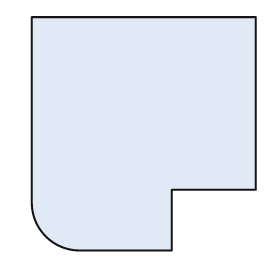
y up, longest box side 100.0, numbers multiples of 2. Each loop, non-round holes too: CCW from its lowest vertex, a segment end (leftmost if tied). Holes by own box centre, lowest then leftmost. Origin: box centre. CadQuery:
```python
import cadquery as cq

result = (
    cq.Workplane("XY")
    .moveTo(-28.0, -50.0)
    .lineTo(12.0, -50.0)
    .lineTo(12.0, -24.0)
    .lineTo(48.0, -24.0)
    .lineTo(48.0, 50.0)
    .lineTo(-48.0, 50.0)
    .lineTo(-48.0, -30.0)
    .threePointArc((-42.0, -44.0), (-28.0, -50.0))
    .close()
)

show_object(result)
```